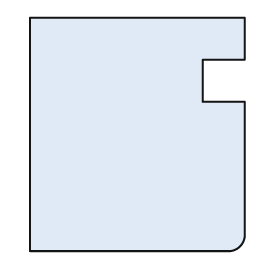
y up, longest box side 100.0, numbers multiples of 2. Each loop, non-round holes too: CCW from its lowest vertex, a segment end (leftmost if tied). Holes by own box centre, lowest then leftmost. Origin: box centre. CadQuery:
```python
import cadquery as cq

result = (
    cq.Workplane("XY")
    .moveTo(-46.0, -50.0)
    .lineTo(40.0, -50.0)
    .threePointArc((44.0, -48.0), (46.0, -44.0))
    .lineTo(46.0, 14.0)
    .lineTo(28.0, 14.0)
    .lineTo(28.0, 32.0)
    .lineTo(46.0, 32.0)
    .lineTo(46.0, 50.0)
    .lineTo(-46.0, 50.0)
    .close()
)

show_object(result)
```